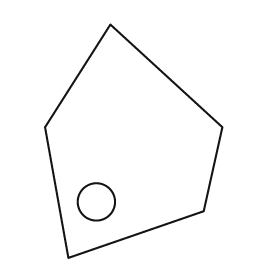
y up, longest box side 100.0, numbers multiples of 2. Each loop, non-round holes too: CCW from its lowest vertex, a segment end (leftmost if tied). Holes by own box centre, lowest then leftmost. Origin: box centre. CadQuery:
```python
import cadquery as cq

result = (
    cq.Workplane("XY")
    .moveTo(-28.0, -50.0)
    .lineTo(30.0, -30.0)
    .lineTo(38.0, 6.0)
    .lineTo(-10.0, 50.0)
    .lineTo(-38.0, 6.0)
    .close()
    .moveTo(-16.0, -26.0)
    .circle(8.0)
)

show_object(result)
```